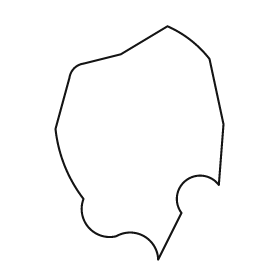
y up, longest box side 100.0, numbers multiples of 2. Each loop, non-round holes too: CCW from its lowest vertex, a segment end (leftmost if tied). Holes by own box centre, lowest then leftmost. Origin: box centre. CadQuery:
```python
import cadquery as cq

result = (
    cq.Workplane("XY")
    .moveTo(8.0, -50.0)
    .lineTo(18.0, -30.0)
    .threePointArc((20.0, -16.0), (34.0, -18.0))
    .lineTo(36.0, 8.0)
    .lineTo(30.0, 36.0)
    .threePointArc((22.0, 44.0), (12.0, 50.0))
    .lineTo(-8.0, 38.0)
    .lineTo(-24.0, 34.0)
    .threePointArc((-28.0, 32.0), (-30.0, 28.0))
    .lineTo(-36.0, 6.0)
    .threePointArc((-32.0, -10.0), (-24.0, -24.0))
    .threePointArc((-22.0, -36.0), (-10.0, -40.0))
    .threePointArc((2.0, -40.0), (8.0, -50.0))
    .close()
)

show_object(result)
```